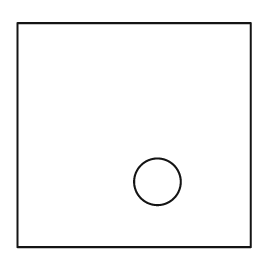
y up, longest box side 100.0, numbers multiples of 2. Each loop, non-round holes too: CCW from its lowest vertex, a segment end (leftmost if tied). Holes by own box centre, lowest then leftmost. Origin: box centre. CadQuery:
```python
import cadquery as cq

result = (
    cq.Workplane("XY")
    .moveTo(-50.0, -48.0)
    .lineTo(50.0, -48.0)
    .lineTo(50.0, 48.0)
    .lineTo(-50.0, 48.0)
    .close()
    .moveTo(10.0, -20.0)
    .circle(10.0)
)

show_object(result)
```